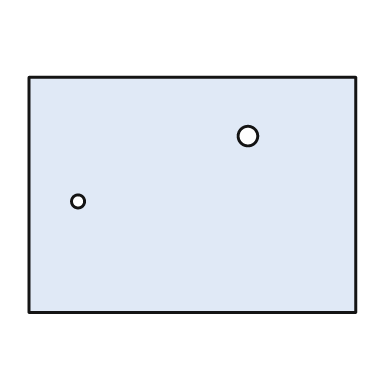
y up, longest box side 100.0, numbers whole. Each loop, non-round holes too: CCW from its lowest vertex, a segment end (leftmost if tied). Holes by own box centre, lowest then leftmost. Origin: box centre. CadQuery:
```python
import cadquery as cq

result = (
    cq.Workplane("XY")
    .moveTo(-50.0, -36.0)
    .lineTo(50.0, -36.0)
    .lineTo(50.0, 36.0)
    .lineTo(-50.0, 36.0)
    .close()
    .moveTo(-35.0, -2.0)
    .circle(2.0)
    .moveTo(17.0, 18.0)
    .circle(3.0)
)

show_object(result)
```